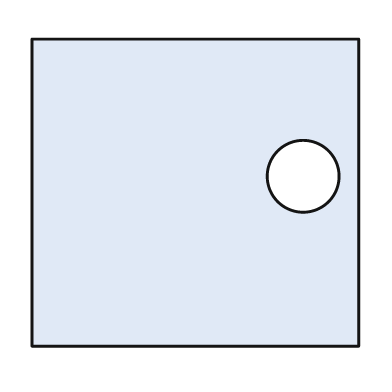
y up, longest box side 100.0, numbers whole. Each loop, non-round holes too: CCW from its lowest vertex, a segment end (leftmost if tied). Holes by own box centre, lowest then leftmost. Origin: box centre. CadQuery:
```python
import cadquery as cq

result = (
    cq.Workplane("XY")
    .moveTo(-50.0, -47.0)
    .lineTo(50.0, -47.0)
    .lineTo(50.0, 47.0)
    .lineTo(-50.0, 47.0)
    .close()
    .moveTo(33.0, 5.0)
    .circle(11.0)
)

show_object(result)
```